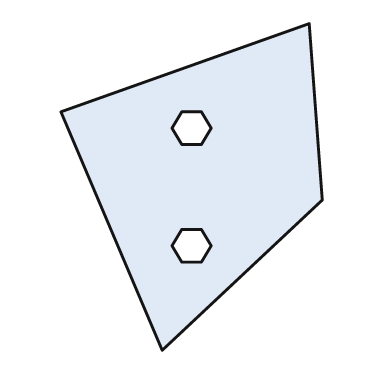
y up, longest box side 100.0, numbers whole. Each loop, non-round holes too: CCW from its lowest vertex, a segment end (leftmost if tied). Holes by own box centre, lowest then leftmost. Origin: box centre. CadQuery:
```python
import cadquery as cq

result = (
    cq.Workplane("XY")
    .moveTo(-9.0, -50.0)
    .lineTo(40.0, -4.0)
    .lineTo(36.0, 50.0)
    .lineTo(-40.0, 23.0)
    .close()
    .moveTo(-3.0, -23.0)
    .lineTo(3.0, -23.0)
    .lineTo(6.0, -18.0)
    .lineTo(3.0, -13.0)
    .lineTo(-3.0, -13.0)
    .lineTo(-6.0, -18.0)
    .close()
    .moveTo(-3.0, 13.0)
    .lineTo(3.0, 13.0)
    .lineTo(6.0, 18.0)
    .lineTo(3.0, 23.0)
    .lineTo(-3.0, 23.0)
    .lineTo(-6.0, 18.0)
    .close()
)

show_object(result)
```